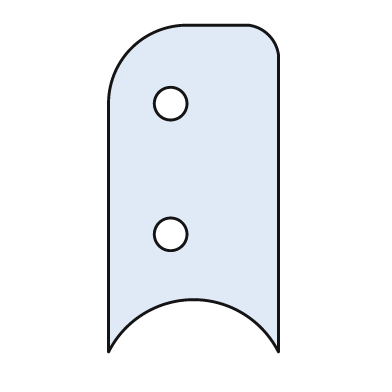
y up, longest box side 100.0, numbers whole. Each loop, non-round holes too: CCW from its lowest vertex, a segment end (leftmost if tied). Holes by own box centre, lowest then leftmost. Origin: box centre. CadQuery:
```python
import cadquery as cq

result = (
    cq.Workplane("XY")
    .moveTo(-26.0, -50.0)
    .threePointArc((0.0, -34.0), (26.0, -50.0))
    .lineTo(26.0, 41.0)
    .threePointArc((23.0, 47.0), (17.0, 50.0))
    .lineTo(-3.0, 50.0)
    .threePointArc((-19.0, 43.0), (-26.0, 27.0))
    .close()
    .moveTo(-7.0, -14.0)
    .circle(5.0)
    .moveTo(-7.0, 26.0)
    .circle(5.0)
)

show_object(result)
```